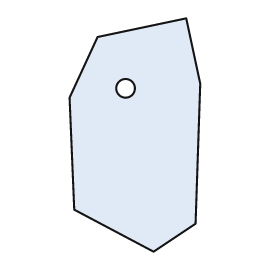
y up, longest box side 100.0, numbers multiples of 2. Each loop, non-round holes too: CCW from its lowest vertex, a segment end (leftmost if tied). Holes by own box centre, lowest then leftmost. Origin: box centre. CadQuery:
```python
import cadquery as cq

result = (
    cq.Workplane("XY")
    .moveTo(8.0, -50.0)
    .lineTo(26.0, -38.0)
    .lineTo(28.0, 22.0)
    .lineTo(22.0, 50.0)
    .lineTo(-16.0, 42.0)
    .lineTo(-28.0, 16.0)
    .lineTo(-26.0, -32.0)
    .close()
    .moveTo(-4.0, 20.0)
    .circle(4.0)
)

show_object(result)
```